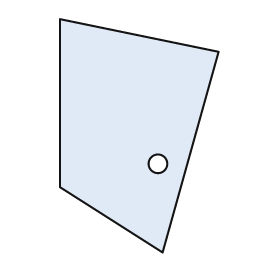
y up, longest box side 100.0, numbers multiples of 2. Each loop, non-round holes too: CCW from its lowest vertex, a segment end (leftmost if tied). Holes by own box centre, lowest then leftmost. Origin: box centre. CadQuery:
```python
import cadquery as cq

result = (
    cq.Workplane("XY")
    .moveTo(10.0, -50.0)
    .lineTo(34.0, 36.0)
    .lineTo(-34.0, 50.0)
    .lineTo(-34.0, -22.0)
    .close()
    .moveTo(8.0, -12.0)
    .circle(4.0)
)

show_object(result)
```